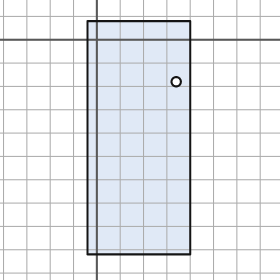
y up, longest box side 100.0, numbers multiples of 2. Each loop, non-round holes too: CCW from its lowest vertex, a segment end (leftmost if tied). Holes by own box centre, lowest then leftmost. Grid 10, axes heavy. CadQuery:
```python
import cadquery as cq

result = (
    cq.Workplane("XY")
    .moveTo(-4.0, -92.0)
    .lineTo(40.0, -92.0)
    .lineTo(40.0, 8.0)
    .lineTo(-4.0, 8.0)
    .close()
    .moveTo(34.0, -18.0)
    .circle(2.0)
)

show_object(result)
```